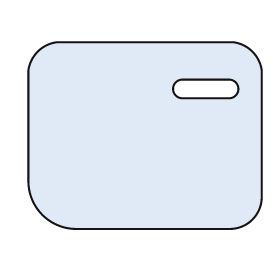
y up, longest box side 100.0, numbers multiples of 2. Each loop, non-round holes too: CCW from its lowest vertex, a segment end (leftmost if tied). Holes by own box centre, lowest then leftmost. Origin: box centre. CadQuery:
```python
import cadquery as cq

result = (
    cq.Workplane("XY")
    .moveTo(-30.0, -40.0)
    .lineTo(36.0, -40.0)
    .threePointArc((46.0, -36.0), (50.0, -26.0))
    .lineTo(50.0, 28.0)
    .threePointArc((46.0, 36.0), (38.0, 40.0))
    .lineTo(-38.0, 40.0)
    .threePointArc((-46.0, 36.0), (-50.0, 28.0))
    .lineTo(-50.0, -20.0)
    .threePointArc((-44.0, -34.0), (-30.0, -40.0))
    .close()
    .moveTo(16.0, 16.0)
    .lineTo(36.0, 16.0)
    .threePointArc((40.0, 20.0), (36.0, 24.0))
    .lineTo(16.0, 24.0)
    .threePointArc((12.0, 20.0), (16.0, 16.0))
    .close()
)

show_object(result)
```